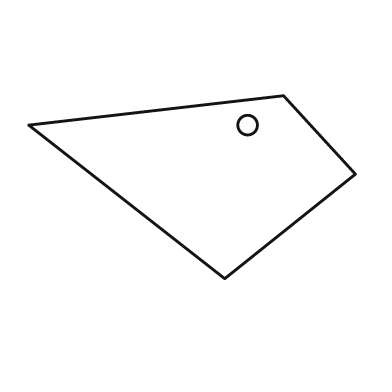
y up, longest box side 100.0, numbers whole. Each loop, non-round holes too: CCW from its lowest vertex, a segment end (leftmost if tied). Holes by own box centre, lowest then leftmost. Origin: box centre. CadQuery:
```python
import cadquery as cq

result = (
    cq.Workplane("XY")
    .moveTo(10.0, -28.0)
    .lineTo(50.0, 4.0)
    .lineTo(28.0, 28.0)
    .lineTo(-50.0, 19.0)
    .close()
    .moveTo(17.0, 19.0)
    .circle(3.0)
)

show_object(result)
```